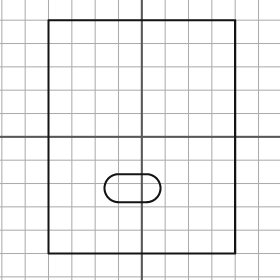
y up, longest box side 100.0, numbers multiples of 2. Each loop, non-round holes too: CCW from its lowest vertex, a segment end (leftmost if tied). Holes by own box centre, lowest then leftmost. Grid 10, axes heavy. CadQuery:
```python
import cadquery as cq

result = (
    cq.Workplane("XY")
    .moveTo(-40.0, -50.0)
    .lineTo(40.0, -50.0)
    .lineTo(40.0, 50.0)
    .lineTo(-40.0, 50.0)
    .close()
    .moveTo(-10.0, -28.0)
    .lineTo(2.0, -28.0)
    .threePointArc((8.0, -22.0), (2.0, -16.0))
    .lineTo(-10.0, -16.0)
    .threePointArc((-16.0, -22.0), (-10.0, -28.0))
    .close()
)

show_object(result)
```